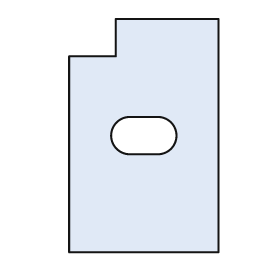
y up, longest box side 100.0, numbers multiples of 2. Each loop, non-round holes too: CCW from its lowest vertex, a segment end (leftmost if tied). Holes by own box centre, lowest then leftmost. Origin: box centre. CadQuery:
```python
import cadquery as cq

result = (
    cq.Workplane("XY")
    .moveTo(-32.0, -50.0)
    .lineTo(32.0, -50.0)
    .lineTo(32.0, 50.0)
    .lineTo(-12.0, 50.0)
    .lineTo(-12.0, 34.0)
    .lineTo(-32.0, 34.0)
    .close()
    .moveTo(-6.0, -8.0)
    .lineTo(6.0, -8.0)
    .threePointArc((14.0, 0.0), (6.0, 8.0))
    .lineTo(-6.0, 8.0)
    .threePointArc((-14.0, 0.0), (-6.0, -8.0))
    .close()
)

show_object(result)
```